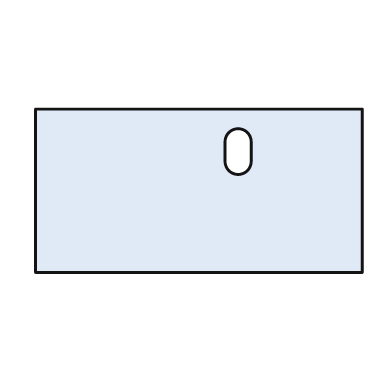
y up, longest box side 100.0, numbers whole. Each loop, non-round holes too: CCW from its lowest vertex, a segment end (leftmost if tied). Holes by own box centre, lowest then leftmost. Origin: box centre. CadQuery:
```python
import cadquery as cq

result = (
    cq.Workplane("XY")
    .moveTo(-50.0, -25.0)
    .lineTo(50.0, -25.0)
    .lineTo(50.0, 25.0)
    .lineTo(-50.0, 25.0)
    .close()
    .moveTo(8.0, 9.0)
    .threePointArc((12.0, 5.0), (16.0, 9.0))
    .lineTo(16.0, 15.0)
    .threePointArc((12.0, 19.0), (8.0, 15.0))
    .close()
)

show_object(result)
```